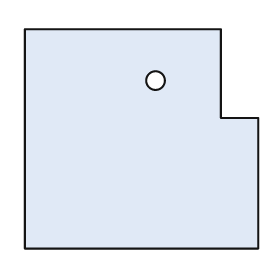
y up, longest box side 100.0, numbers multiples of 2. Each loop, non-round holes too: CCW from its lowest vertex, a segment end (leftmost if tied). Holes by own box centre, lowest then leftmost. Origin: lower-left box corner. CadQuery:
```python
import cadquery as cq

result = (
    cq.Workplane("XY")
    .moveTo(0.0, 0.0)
    .lineTo(100.0, 0.0)
    .lineTo(100.0, 56.0)
    .lineTo(84.0, 56.0)
    .lineTo(84.0, 94.0)
    .lineTo(0.0, 94.0)
    .close()
    .moveTo(56.0, 72.0)
    .circle(4.0)
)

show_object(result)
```